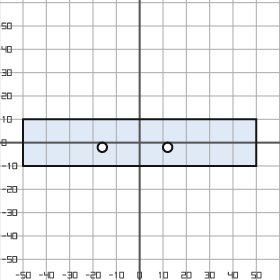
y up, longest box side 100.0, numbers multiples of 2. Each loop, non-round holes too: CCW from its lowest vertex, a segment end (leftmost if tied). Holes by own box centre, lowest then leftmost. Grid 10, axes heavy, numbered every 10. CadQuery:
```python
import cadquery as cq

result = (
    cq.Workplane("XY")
    .moveTo(-50.0, -10.0)
    .lineTo(50.0, -10.0)
    .lineTo(50.0, 10.0)
    .lineTo(-50.0, 10.0)
    .close()
    .moveTo(-16.0, -2.0)
    .circle(2.0)
    .moveTo(12.0, -2.0)
    .circle(2.0)
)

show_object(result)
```